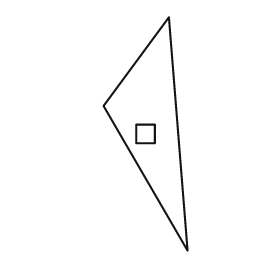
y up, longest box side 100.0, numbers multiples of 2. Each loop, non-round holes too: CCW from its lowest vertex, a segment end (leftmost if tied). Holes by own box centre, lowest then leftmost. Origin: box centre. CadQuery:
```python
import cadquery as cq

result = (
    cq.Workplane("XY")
    .moveTo(18.0, -50.0)
    .lineTo(10.0, 50.0)
    .lineTo(-18.0, 12.0)
    .close()
    .moveTo(-4.0, -4.0)
    .lineTo(4.0, -4.0)
    .lineTo(4.0, 4.0)
    .lineTo(-4.0, 4.0)
    .close()
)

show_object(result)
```